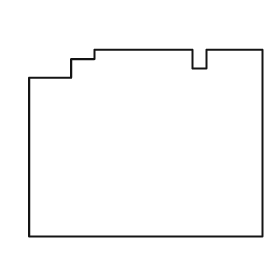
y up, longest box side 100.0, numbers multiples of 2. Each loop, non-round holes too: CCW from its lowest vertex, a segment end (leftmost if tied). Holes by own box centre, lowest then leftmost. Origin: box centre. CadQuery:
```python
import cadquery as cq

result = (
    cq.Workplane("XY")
    .moveTo(-50.0, -40.0)
    .lineTo(50.0, -40.0)
    .lineTo(50.0, 40.0)
    .lineTo(26.0, 40.0)
    .lineTo(26.0, 32.0)
    .lineTo(20.0, 32.0)
    .lineTo(20.0, 40.0)
    .lineTo(-22.0, 40.0)
    .lineTo(-22.0, 36.0)
    .lineTo(-32.0, 36.0)
    .lineTo(-32.0, 28.0)
    .lineTo(-50.0, 28.0)
    .close()
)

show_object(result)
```